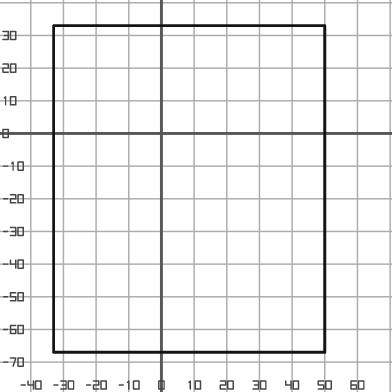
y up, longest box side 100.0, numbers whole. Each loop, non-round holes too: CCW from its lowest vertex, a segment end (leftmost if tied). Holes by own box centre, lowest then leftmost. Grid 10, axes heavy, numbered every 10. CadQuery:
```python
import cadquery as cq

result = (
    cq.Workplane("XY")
    .moveTo(-33.0, -67.0)
    .lineTo(50.0, -67.0)
    .lineTo(50.0, 33.0)
    .lineTo(-33.0, 33.0)
    .close()
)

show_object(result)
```